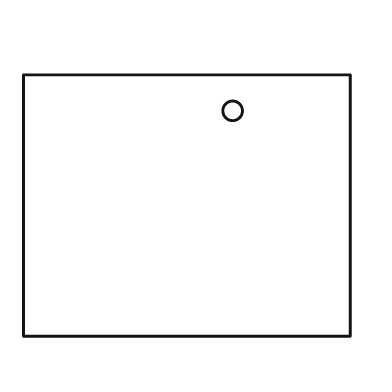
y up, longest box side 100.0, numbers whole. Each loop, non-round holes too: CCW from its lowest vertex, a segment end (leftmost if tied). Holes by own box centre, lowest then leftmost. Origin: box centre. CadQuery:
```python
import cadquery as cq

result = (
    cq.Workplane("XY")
    .moveTo(-50.0, -40.0)
    .lineTo(50.0, -40.0)
    .lineTo(50.0, 40.0)
    .lineTo(-50.0, 40.0)
    .close()
    .moveTo(14.0, 29.0)
    .circle(3.0)
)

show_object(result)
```